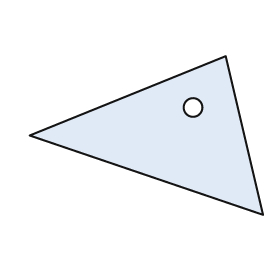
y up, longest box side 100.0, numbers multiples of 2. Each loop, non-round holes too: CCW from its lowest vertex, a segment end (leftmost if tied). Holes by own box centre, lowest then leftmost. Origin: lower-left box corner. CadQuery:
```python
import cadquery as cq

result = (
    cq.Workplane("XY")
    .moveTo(100.0, 0.0)
    .lineTo(84.0, 68.0)
    .lineTo(0.0, 34.0)
    .close()
    .moveTo(70.0, 46.0)
    .circle(4.0)
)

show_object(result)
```